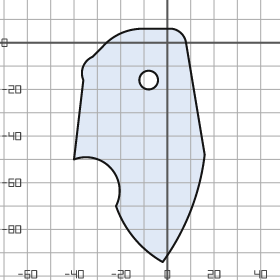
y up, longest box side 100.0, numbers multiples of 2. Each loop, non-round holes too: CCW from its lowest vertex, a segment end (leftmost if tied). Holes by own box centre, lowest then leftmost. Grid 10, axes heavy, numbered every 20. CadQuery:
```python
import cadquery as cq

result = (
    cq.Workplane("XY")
    .moveTo(-2.0, -94.0)
    .threePointArc((10.0, -72.0), (16.0, -48.0))
    .lineTo(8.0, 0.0)
    .threePointArc((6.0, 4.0), (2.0, 6.0))
    .lineTo(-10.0, 6.0)
    .threePointArc((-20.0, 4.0), (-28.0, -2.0))
    .lineTo(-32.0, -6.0)
    .threePointArc((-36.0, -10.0), (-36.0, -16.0))
    .lineTo(-40.0, -50.0)
    .threePointArc((-24.0, -54.0), (-22.0, -70.0))
    .threePointArc((-14.0, -84.0), (-2.0, -94.0))
    .close()
    .moveTo(-8.0, -16.0)
    .circle(4.0)
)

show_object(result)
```